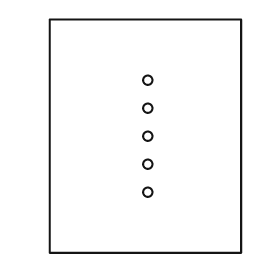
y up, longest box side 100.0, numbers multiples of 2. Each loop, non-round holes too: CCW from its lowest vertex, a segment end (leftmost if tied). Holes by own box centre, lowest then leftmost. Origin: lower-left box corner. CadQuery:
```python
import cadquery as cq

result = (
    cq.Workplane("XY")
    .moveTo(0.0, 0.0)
    .lineTo(82.0, 0.0)
    .lineTo(82.0, 100.0)
    .lineTo(0.0, 100.0)
    .close()
    .moveTo(42.0, 26.0)
    .circle(2.0)
    .moveTo(42.0, 38.0)
    .circle(2.0)
    .moveTo(42.0, 50.0)
    .circle(2.0)
    .moveTo(42.0, 62.0)
    .circle(2.0)
    .moveTo(42.0, 74.0)
    .circle(2.0)
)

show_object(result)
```